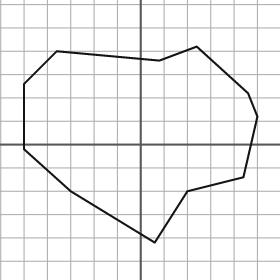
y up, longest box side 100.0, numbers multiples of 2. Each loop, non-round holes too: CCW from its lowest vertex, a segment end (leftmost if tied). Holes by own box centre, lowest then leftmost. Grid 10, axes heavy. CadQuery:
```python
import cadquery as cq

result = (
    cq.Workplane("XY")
    .moveTo(6.0, -42.0)
    .lineTo(20.0, -20.0)
    .lineTo(44.0, -14.0)
    .lineTo(50.0, 12.0)
    .lineTo(46.0, 22.0)
    .lineTo(24.0, 42.0)
    .lineTo(8.0, 36.0)
    .lineTo(-36.0, 40.0)
    .lineTo(-50.0, 26.0)
    .lineTo(-50.0, -2.0)
    .lineTo(-30.0, -20.0)
    .close()
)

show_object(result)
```